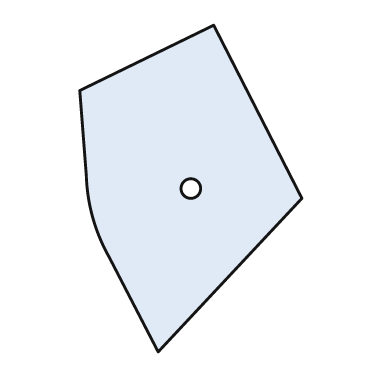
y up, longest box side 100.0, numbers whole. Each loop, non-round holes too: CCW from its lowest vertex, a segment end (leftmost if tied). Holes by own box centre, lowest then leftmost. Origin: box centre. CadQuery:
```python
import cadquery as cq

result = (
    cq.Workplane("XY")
    .moveTo(-10.0, -50.0)
    .lineTo(34.0, -3.0)
    .lineTo(7.0, 50.0)
    .lineTo(-34.0, 30.0)
    .lineTo(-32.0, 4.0)
    .threePointArc((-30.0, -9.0), (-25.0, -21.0))
    .close()
    .moveTo(0.0, 0.0)
    .circle(3.0)
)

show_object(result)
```